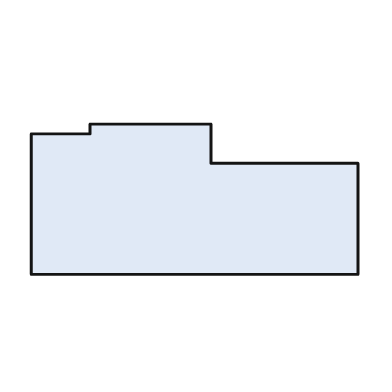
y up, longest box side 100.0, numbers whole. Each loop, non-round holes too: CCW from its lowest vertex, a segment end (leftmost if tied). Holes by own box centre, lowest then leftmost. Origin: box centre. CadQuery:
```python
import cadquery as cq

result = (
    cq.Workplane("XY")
    .moveTo(-50.0, -23.0)
    .lineTo(50.0, -23.0)
    .lineTo(50.0, 11.0)
    .lineTo(5.0, 11.0)
    .lineTo(5.0, 23.0)
    .lineTo(-32.0, 23.0)
    .lineTo(-32.0, 20.0)
    .lineTo(-50.0, 20.0)
    .close()
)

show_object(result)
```